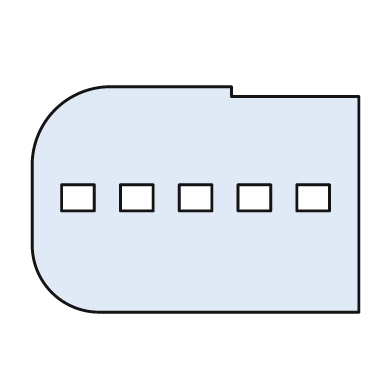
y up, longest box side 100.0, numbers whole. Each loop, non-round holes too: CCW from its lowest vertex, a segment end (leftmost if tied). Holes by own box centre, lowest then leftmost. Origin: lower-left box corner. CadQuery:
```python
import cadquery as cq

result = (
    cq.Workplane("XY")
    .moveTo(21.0, 0.0)
    .lineTo(100.0, 0.0)
    .lineTo(100.0, 66.0)
    .lineTo(61.0, 66.0)
    .lineTo(61.0, 69.0)
    .lineTo(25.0, 69.0)
    .threePointArc((7.0, 62.0), (0.0, 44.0))
    .lineTo(0.0, 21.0)
    .threePointArc((6.0, 6.0), (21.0, 0.0))
    .close()
    .moveTo(9.0, 31.0)
    .lineTo(19.0, 31.0)
    .lineTo(19.0, 39.0)
    .lineTo(9.0, 39.0)
    .close()
    .moveTo(27.0, 31.0)
    .lineTo(37.0, 31.0)
    .lineTo(37.0, 39.0)
    .lineTo(27.0, 39.0)
    .close()
    .moveTo(45.0, 31.0)
    .lineTo(55.0, 31.0)
    .lineTo(55.0, 39.0)
    .lineTo(45.0, 39.0)
    .close()
    .moveTo(63.0, 31.0)
    .lineTo(73.0, 31.0)
    .lineTo(73.0, 39.0)
    .lineTo(63.0, 39.0)
    .close()
    .moveTo(81.0, 31.0)
    .lineTo(91.0, 31.0)
    .lineTo(91.0, 39.0)
    .lineTo(81.0, 39.0)
    .close()
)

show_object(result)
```